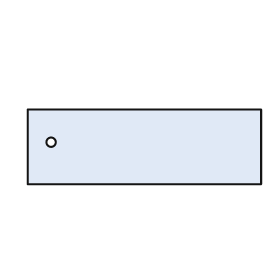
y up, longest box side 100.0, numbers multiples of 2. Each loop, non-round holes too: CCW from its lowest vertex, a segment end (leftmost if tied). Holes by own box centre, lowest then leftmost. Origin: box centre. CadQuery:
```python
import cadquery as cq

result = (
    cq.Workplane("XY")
    .moveTo(-50.0, -16.0)
    .lineTo(50.0, -16.0)
    .lineTo(50.0, 16.0)
    .lineTo(-50.0, 16.0)
    .close()
    .moveTo(-40.0, 2.0)
    .circle(2.0)
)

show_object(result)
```